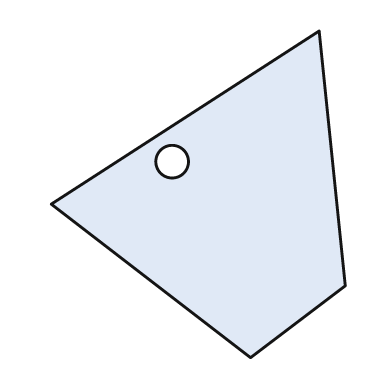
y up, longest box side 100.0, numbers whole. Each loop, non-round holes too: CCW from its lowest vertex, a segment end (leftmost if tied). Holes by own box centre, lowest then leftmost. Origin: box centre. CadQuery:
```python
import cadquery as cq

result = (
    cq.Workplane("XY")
    .moveTo(16.0, -50.0)
    .lineTo(45.0, -28.0)
    .lineTo(37.0, 50.0)
    .lineTo(-45.0, -3.0)
    .close()
    .moveTo(-8.0, 10.0)
    .circle(5.0)
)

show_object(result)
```